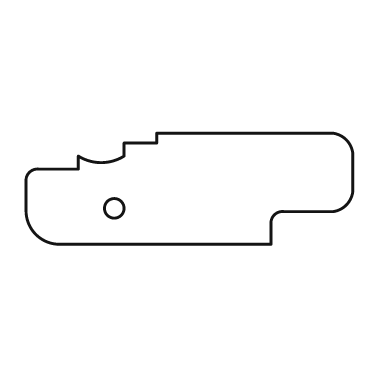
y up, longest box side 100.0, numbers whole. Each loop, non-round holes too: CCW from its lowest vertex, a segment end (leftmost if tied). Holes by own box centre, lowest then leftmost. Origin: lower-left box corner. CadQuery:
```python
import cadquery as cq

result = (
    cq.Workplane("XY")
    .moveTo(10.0, 0.0)
    .lineTo(75.0, 0.0)
    .lineTo(75.0, 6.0)
    .threePointArc((76.0, 9.0), (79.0, 10.0))
    .lineTo(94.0, 10.0)
    .threePointArc((98.0, 12.0), (100.0, 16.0))
    .lineTo(100.0, 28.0)
    .threePointArc((98.0, 32.0), (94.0, 34.0))
    .lineTo(40.0, 34.0)
    .lineTo(40.0, 31.0)
    .lineTo(30.0, 31.0)
    .lineTo(30.0, 27.0)
    .threePointArc((23.0, 25.0), (16.0, 27.0))
    .lineTo(16.0, 23.0)
    .lineTo(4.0, 23.0)
    .threePointArc((1.0, 22.0), (0.0, 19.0))
    .lineTo(0.0, 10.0)
    .threePointArc((3.0, 3.0), (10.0, 0.0))
    .close()
    .moveTo(27.0, 11.0)
    .circle(3.0)
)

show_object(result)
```